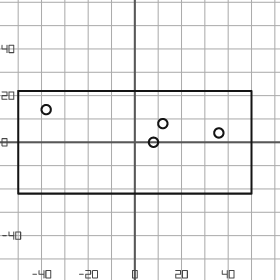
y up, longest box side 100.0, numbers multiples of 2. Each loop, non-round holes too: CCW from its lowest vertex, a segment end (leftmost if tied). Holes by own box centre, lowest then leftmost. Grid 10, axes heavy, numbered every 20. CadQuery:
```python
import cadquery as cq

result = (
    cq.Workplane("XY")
    .moveTo(-50.0, -22.0)
    .lineTo(50.0, -22.0)
    .lineTo(50.0, 22.0)
    .lineTo(-50.0, 22.0)
    .close()
    .moveTo(8.0, 0.0)
    .circle(2.0)
    .moveTo(36.0, 4.0)
    .circle(2.0)
    .moveTo(12.0, 8.0)
    .circle(2.0)
    .moveTo(-38.0, 14.0)
    .circle(2.0)
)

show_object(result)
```